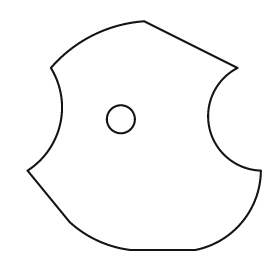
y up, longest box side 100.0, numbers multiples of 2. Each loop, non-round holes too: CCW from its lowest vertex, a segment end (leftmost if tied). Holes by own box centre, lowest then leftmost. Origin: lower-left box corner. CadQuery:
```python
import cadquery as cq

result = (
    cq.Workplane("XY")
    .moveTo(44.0, 0.0)
    .lineTo(72.0, 0.0)
    .threePointArc((92.0, 12.0), (100.0, 34.0))
    .threePointArc((78.0, 52.0), (90.0, 78.0))
    .lineTo(50.0, 98.0)
    .threePointArc((28.0, 92.0), (10.0, 78.0))
    .threePointArc((14.0, 54.0), (0.0, 34.0))
    .lineTo(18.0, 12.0)
    .threePointArc((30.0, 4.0), (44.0, 0.0))
    .close()
    .moveTo(40.0, 56.0)
    .circle(6.0)
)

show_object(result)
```